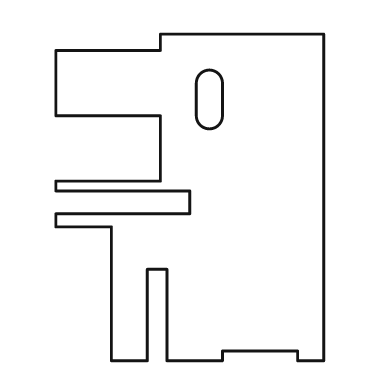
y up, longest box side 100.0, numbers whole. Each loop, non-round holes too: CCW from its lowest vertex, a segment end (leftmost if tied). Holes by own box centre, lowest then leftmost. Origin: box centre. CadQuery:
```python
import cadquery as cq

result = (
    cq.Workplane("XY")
    .moveTo(-24.0, -50.0)
    .lineTo(-13.0, -50.0)
    .lineTo(-13.0, -22.0)
    .lineTo(-7.0, -22.0)
    .lineTo(-7.0, -50.0)
    .lineTo(10.0, -50.0)
    .lineTo(10.0, -47.0)
    .lineTo(33.0, -47.0)
    .lineTo(33.0, -50.0)
    .lineTo(41.0, -50.0)
    .lineTo(41.0, 50.0)
    .lineTo(-9.0, 50.0)
    .lineTo(-9.0, 45.0)
    .lineTo(-41.0, 45.0)
    .lineTo(-41.0, 25.0)
    .lineTo(-9.0, 25.0)
    .lineTo(-9.0, 5.0)
    .lineTo(-41.0, 5.0)
    .lineTo(-41.0, 2.0)
    .lineTo(0.0, 2.0)
    .lineTo(0.0, -5.0)
    .lineTo(-41.0, -5.0)
    .lineTo(-41.0, -9.0)
    .lineTo(-24.0, -9.0)
    .close()
    .moveTo(2.0, 25.0)
    .threePointArc((6.0, 21.0), (10.0, 25.0))
    .lineTo(10.0, 35.0)
    .threePointArc((6.0, 39.0), (2.0, 35.0))
    .close()
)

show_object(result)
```